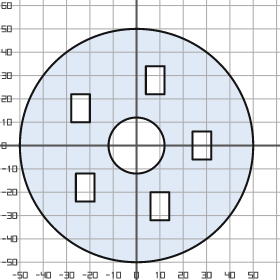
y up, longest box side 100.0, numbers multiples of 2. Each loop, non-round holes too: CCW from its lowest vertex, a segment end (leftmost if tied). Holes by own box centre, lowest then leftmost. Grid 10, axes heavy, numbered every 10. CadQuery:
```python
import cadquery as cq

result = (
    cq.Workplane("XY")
    .moveTo(0.0, 0.0)
    .circle(50.0)
    .moveTo(6.0, -32.0)
    .lineTo(14.0, -32.0)
    .lineTo(14.0, -20.0)
    .lineTo(6.0, -20.0)
    .close()
    .moveTo(-26.0, -24.0)
    .lineTo(-18.0, -24.0)
    .lineTo(-18.0, -12.0)
    .lineTo(-26.0, -12.0)
    .close()
    .moveTo(0.0, 0.0)
    .circle(12.0)
    .moveTo(24.0, -6.0)
    .lineTo(32.0, -6.0)
    .lineTo(32.0, 6.0)
    .lineTo(24.0, 6.0)
    .close()
    .moveTo(-28.0, 10.0)
    .lineTo(-20.0, 10.0)
    .lineTo(-20.0, 22.0)
    .lineTo(-28.0, 22.0)
    .close()
    .moveTo(4.0, 22.0)
    .lineTo(12.0, 22.0)
    .lineTo(12.0, 34.0)
    .lineTo(4.0, 34.0)
    .close()
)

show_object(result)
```